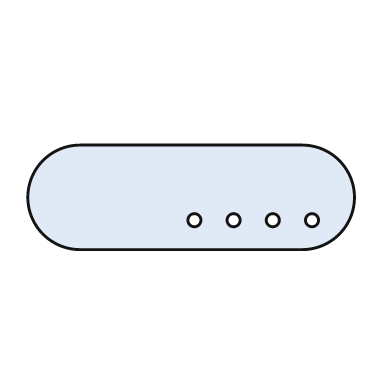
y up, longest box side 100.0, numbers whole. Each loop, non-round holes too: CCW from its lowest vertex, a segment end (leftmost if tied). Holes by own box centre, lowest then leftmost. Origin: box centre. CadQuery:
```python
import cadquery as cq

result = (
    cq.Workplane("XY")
    .moveTo(-34.0, -16.0)
    .lineTo(34.0, -16.0)
    .threePointArc((50.0, 0.0), (34.0, 16.0))
    .lineTo(-34.0, 16.0)
    .threePointArc((-50.0, 0.0), (-34.0, -16.0))
    .close()
    .moveTo(1.0, -7.0)
    .circle(2.0)
    .moveTo(13.0, -7.0)
    .circle(2.0)
    .moveTo(25.0, -7.0)
    .circle(2.0)
    .moveTo(37.0, -7.0)
    .circle(2.0)
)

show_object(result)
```